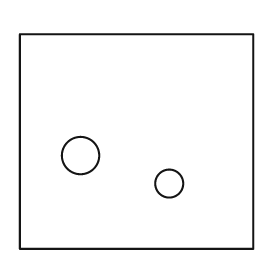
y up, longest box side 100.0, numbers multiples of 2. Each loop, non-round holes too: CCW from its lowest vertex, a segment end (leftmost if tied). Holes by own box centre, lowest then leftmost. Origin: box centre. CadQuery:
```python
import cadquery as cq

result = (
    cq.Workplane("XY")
    .moveTo(-50.0, -46.0)
    .lineTo(50.0, -46.0)
    .lineTo(50.0, 46.0)
    .lineTo(-50.0, 46.0)
    .close()
    .moveTo(14.0, -18.0)
    .circle(6.0)
    .moveTo(-24.0, -6.0)
    .circle(8.0)
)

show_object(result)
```